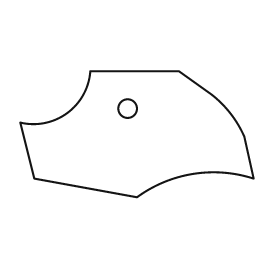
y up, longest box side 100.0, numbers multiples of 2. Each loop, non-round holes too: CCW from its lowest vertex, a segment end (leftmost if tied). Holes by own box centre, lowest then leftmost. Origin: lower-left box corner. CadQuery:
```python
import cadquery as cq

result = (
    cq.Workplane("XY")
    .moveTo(50.0, 0.0)
    .threePointArc((74.0, 10.0), (100.0, 8.0))
    .lineTo(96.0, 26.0)
    .threePointArc((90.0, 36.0), (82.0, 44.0))
    .lineTo(68.0, 54.0)
    .lineTo(30.0, 54.0)
    .threePointArc((20.0, 36.0), (0.0, 32.0))
    .lineTo(6.0, 8.0)
    .close()
    .moveTo(46.0, 38.0)
    .circle(4.0)
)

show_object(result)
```